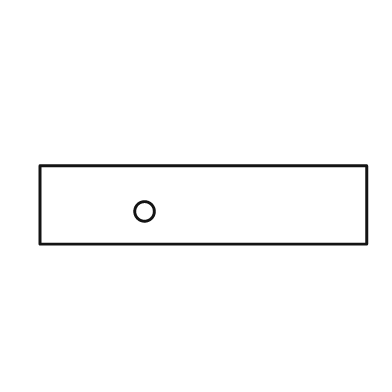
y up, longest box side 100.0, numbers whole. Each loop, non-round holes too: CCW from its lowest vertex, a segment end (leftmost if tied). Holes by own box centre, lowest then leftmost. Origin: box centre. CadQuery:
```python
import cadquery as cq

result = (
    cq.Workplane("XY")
    .moveTo(-50.0, -12.0)
    .lineTo(50.0, -12.0)
    .lineTo(50.0, 12.0)
    .lineTo(-50.0, 12.0)
    .close()
    .moveTo(-18.0, -2.0)
    .circle(3.0)
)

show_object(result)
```